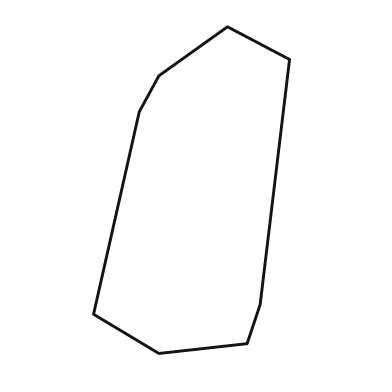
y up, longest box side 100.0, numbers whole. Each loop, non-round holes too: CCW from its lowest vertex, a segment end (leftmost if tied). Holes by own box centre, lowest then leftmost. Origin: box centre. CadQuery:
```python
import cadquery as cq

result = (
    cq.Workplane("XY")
    .moveTo(-10.0, -50.0)
    .lineTo(17.0, -47.0)
    .lineTo(21.0, -35.0)
    .lineTo(30.0, 40.0)
    .lineTo(11.0, 50.0)
    .lineTo(-10.0, 35.0)
    .lineTo(-16.0, 24.0)
    .lineTo(-30.0, -38.0)
    .close()
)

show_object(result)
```